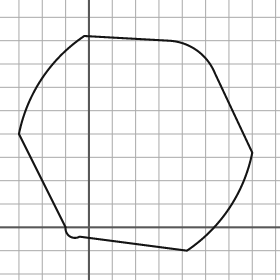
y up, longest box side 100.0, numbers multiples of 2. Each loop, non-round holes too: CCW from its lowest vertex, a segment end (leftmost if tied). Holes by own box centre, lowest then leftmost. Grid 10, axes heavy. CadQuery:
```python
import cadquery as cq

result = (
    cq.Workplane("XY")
    .moveTo(42.0, -10.0)
    .threePointArc((60.0, 8.0), (70.0, 32.0))
    .lineTo(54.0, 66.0)
    .threePointArc((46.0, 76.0), (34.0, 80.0))
    .lineTo(-2.0, 82.0)
    .threePointArc((-20.0, 64.0), (-30.0, 40.0))
    .lineTo(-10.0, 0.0)
    .threePointArc((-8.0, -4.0), (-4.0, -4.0))
    .close()
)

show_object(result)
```